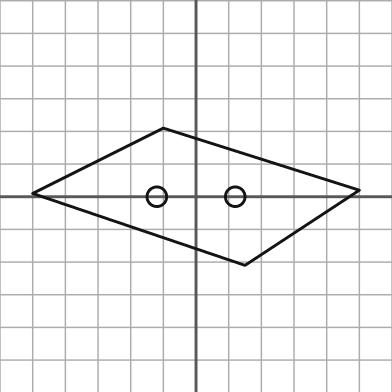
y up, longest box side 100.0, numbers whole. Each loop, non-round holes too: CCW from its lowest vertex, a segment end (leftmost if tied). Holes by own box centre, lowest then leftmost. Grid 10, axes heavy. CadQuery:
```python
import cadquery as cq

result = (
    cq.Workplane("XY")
    .moveTo(15.0, -21.0)
    .lineTo(50.0, 2.0)
    .lineTo(-10.0, 21.0)
    .lineTo(-50.0, 1.0)
    .close()
    .moveTo(-12.0, 0.0)
    .circle(3.0)
    .moveTo(12.0, 0.0)
    .circle(3.0)
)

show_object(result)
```